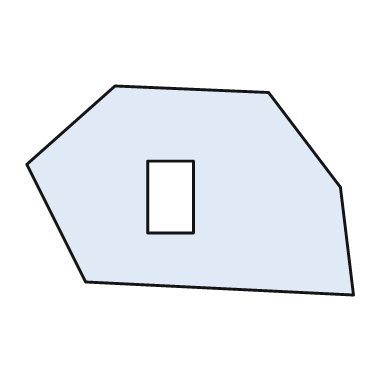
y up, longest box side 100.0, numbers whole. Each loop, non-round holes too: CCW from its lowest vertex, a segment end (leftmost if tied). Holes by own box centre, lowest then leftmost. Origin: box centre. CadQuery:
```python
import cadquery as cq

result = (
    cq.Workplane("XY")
    .moveTo(50.0, -32.0)
    .lineTo(46.0, 1.0)
    .lineTo(24.0, 30.0)
    .lineTo(-23.0, 32.0)
    .lineTo(-50.0, 8.0)
    .lineTo(-32.0, -28.0)
    .close()
    .moveTo(-13.0, -13.0)
    .lineTo(1.0, -13.0)
    .lineTo(1.0, 9.0)
    .lineTo(-13.0, 9.0)
    .close()
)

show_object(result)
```